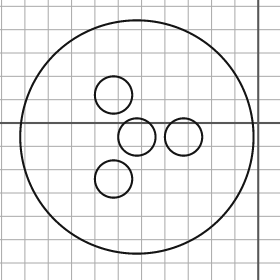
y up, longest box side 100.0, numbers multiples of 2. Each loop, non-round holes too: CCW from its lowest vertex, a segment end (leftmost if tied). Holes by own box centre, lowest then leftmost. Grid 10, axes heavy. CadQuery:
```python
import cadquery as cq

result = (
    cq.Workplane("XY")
    .moveTo(-52.0, -6.0)
    .circle(50.0)
    .moveTo(-62.0, -24.0)
    .circle(8.0)
    .moveTo(-52.0, -6.0)
    .circle(8.0)
    .moveTo(-32.0, -6.0)
    .circle(8.0)
    .moveTo(-62.0, 12.0)
    .circle(8.0)
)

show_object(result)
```